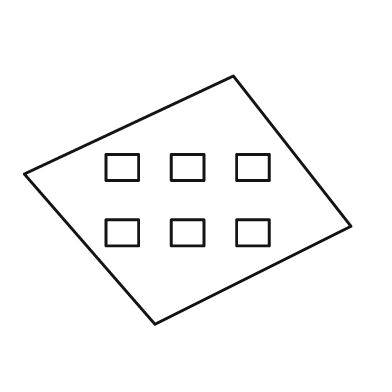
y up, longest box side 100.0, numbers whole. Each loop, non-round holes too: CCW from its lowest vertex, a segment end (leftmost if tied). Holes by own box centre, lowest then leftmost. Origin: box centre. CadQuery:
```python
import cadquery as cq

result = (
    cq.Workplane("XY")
    .moveTo(-10.0, -38.0)
    .lineTo(50.0, -8.0)
    .lineTo(14.0, 38.0)
    .lineTo(-50.0, 8.0)
    .close()
    .moveTo(-25.0, -14.0)
    .lineTo(-15.0, -14.0)
    .lineTo(-15.0, -6.0)
    .lineTo(-25.0, -6.0)
    .close()
    .moveTo(-5.0, -14.0)
    .lineTo(5.0, -14.0)
    .lineTo(5.0, -6.0)
    .lineTo(-5.0, -6.0)
    .close()
    .moveTo(15.0, -14.0)
    .lineTo(25.0, -14.0)
    .lineTo(25.0, -6.0)
    .lineTo(15.0, -6.0)
    .close()
    .moveTo(-25.0, 6.0)
    .lineTo(-15.0, 6.0)
    .lineTo(-15.0, 14.0)
    .lineTo(-25.0, 14.0)
    .close()
    .moveTo(-5.0, 6.0)
    .lineTo(5.0, 6.0)
    .lineTo(5.0, 14.0)
    .lineTo(-5.0, 14.0)
    .close()
    .moveTo(15.0, 6.0)
    .lineTo(25.0, 6.0)
    .lineTo(25.0, 14.0)
    .lineTo(15.0, 14.0)
    .close()
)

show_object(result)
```